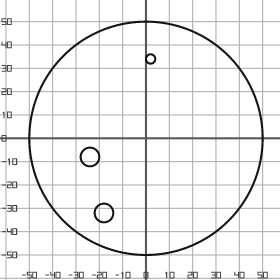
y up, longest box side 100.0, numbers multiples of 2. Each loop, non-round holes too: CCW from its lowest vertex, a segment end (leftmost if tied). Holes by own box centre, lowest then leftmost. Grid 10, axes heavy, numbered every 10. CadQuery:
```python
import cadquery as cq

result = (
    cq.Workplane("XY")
    .moveTo(0.0, 0.0)
    .circle(50.0)
    .moveTo(-18.0, -32.0)
    .circle(4.0)
    .moveTo(-24.0, -8.0)
    .circle(4.0)
    .moveTo(2.0, 34.0)
    .circle(2.0)
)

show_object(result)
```